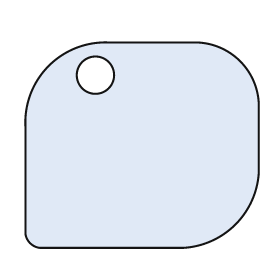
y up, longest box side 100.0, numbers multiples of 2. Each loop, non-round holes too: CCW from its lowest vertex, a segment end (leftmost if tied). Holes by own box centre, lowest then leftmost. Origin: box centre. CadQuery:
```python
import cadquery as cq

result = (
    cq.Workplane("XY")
    .moveTo(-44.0, -44.0)
    .lineTo(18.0, -44.0)
    .threePointArc((40.0, -34.0), (50.0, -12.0))
    .lineTo(50.0, 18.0)
    .threePointArc((42.0, 36.0), (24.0, 44.0))
    .lineTo(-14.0, 44.0)
    .threePointArc((-40.0, 34.0), (-50.0, 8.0))
    .lineTo(-50.0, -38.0)
    .threePointArc((-48.0, -42.0), (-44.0, -44.0))
    .close()
    .moveTo(-20.0, 30.0)
    .circle(8.0)
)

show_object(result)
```